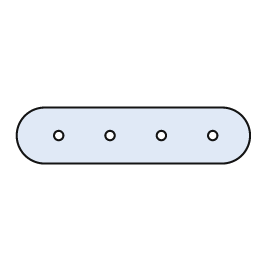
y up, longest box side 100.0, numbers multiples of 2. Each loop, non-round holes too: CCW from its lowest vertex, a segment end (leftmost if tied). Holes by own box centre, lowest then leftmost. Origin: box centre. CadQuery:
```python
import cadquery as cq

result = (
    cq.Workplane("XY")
    .moveTo(-38.0, -12.0)
    .lineTo(38.0, -12.0)
    .threePointArc((50.0, 0.0), (38.0, 12.0))
    .lineTo(-38.0, 12.0)
    .threePointArc((-50.0, 0.0), (-38.0, -12.0))
    .close()
    .moveTo(-32.0, 0.0)
    .circle(2.0)
    .moveTo(-10.0, 0.0)
    .circle(2.0)
    .moveTo(12.0, 0.0)
    .circle(2.0)
    .moveTo(34.0, 0.0)
    .circle(2.0)
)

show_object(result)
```